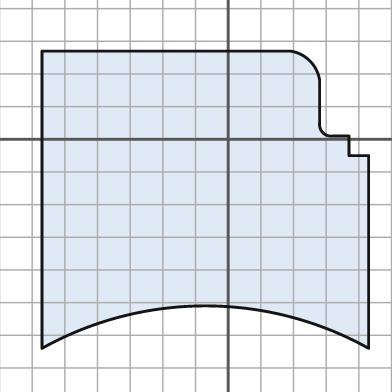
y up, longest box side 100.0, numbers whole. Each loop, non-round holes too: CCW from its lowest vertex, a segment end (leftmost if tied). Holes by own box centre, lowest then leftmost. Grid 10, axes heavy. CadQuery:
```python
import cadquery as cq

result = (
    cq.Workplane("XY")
    .moveTo(-57.0, -64.0)
    .threePointArc((-7.0, -51.0), (43.0, -64.0))
    .lineTo(43.0, -5.0)
    .lineTo(37.0, -5.0)
    .lineTo(37.0, 1.0)
    .lineTo(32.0, 1.0)
    .threePointArc((29.0, 2.0), (28.0, 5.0))
    .lineTo(28.0, 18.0)
    .threePointArc((25.0, 24.0), (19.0, 27.0))
    .lineTo(-57.0, 27.0)
    .close()
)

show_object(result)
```